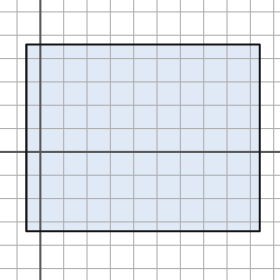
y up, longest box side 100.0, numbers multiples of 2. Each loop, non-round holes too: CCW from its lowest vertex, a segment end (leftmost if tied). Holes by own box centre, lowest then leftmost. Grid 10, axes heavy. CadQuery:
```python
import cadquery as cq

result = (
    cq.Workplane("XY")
    .moveTo(-6.0, -34.0)
    .lineTo(94.0, -34.0)
    .lineTo(94.0, 46.0)
    .lineTo(-6.0, 46.0)
    .close()
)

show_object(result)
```